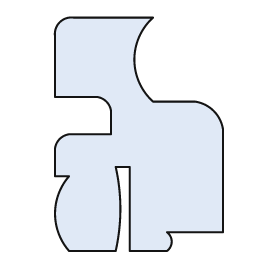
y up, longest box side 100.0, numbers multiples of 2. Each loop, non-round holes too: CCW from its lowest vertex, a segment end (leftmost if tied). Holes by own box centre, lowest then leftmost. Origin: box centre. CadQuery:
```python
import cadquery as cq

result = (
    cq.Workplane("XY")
    .moveTo(-30.0, -50.0)
    .lineTo(-10.0, -50.0)
    .threePointArc((-8.0, -32.0), (-10.0, -14.0))
    .lineTo(-4.0, -14.0)
    .lineTo(-4.0, -50.0)
    .lineTo(12.0, -50.0)
    .threePointArc((14.0, -46.0), (12.0, -42.0))
    .lineTo(36.0, -42.0)
    .lineTo(36.0, 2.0)
    .threePointArc((32.0, 10.0), (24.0, 14.0))
    .lineTo(6.0, 14.0)
    .threePointArc((-2.0, 32.0), (6.0, 50.0))
    .lineTo(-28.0, 50.0)
    .threePointArc((-34.0, 48.0), (-36.0, 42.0))
    .lineTo(-36.0, 16.0)
    .lineTo(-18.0, 16.0)
    .threePointArc((-14.0, 14.0), (-12.0, 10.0))
    .lineTo(-12.0, 0.0)
    .lineTo(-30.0, 0.0)
    .threePointArc((-34.0, -2.0), (-36.0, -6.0))
    .lineTo(-36.0, -18.0)
    .lineTo(-30.0, -18.0)
    .threePointArc((-36.0, -34.0), (-30.0, -50.0))
    .close()
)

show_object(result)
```